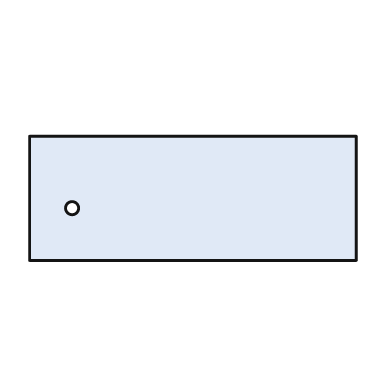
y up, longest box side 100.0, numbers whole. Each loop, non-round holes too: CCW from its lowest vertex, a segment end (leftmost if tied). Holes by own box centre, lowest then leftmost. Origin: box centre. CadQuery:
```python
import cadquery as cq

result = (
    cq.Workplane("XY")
    .moveTo(-50.0, -19.0)
    .lineTo(50.0, -19.0)
    .lineTo(50.0, 19.0)
    .lineTo(-50.0, 19.0)
    .close()
    .moveTo(-37.0, -3.0)
    .circle(2.0)
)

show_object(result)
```